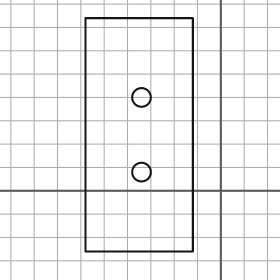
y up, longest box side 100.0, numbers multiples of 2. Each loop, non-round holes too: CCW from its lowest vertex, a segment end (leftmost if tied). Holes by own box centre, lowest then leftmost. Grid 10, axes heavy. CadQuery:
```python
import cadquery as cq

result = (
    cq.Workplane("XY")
    .moveTo(-58.0, -26.0)
    .lineTo(-12.0, -26.0)
    .lineTo(-12.0, 74.0)
    .lineTo(-58.0, 74.0)
    .close()
    .moveTo(-34.0, 8.0)
    .circle(4.0)
    .moveTo(-34.0, 40.0)
    .circle(4.0)
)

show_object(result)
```